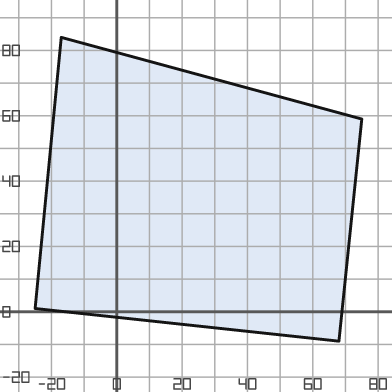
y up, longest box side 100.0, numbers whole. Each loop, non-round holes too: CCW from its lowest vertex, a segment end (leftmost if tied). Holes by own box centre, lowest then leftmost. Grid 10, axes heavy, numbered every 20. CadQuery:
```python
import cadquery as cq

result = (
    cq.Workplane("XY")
    .moveTo(68.0, -9.0)
    .lineTo(75.0, 59.0)
    .lineTo(-17.0, 84.0)
    .lineTo(-25.0, 1.0)
    .close()
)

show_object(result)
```